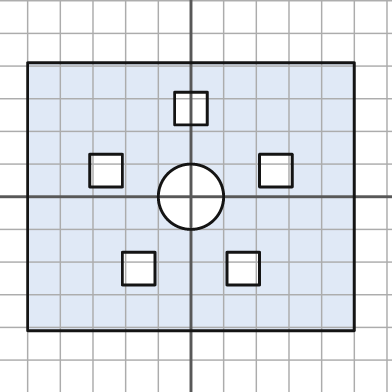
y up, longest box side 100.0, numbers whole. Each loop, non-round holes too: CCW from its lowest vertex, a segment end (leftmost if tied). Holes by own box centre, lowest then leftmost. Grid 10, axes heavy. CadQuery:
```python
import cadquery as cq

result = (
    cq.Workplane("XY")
    .moveTo(-50.0, -41.0)
    .lineTo(50.0, -41.0)
    .lineTo(50.0, 41.0)
    .lineTo(-50.0, 41.0)
    .close()
    .moveTo(-21.0, -27.0)
    .lineTo(-11.0, -27.0)
    .lineTo(-11.0, -17.0)
    .lineTo(-21.0, -17.0)
    .close()
    .moveTo(11.0, -27.0)
    .lineTo(21.0, -27.0)
    .lineTo(21.0, -17.0)
    .lineTo(11.0, -17.0)
    .close()
    .moveTo(0.0, 0.0)
    .circle(10.0)
    .moveTo(-31.0, 3.0)
    .lineTo(-21.0, 3.0)
    .lineTo(-21.0, 13.0)
    .lineTo(-31.0, 13.0)
    .close()
    .moveTo(21.0, 3.0)
    .lineTo(31.0, 3.0)
    .lineTo(31.0, 13.0)
    .lineTo(21.0, 13.0)
    .close()
    .moveTo(-5.0, 22.0)
    .lineTo(5.0, 22.0)
    .lineTo(5.0, 32.0)
    .lineTo(-5.0, 32.0)
    .close()
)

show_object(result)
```